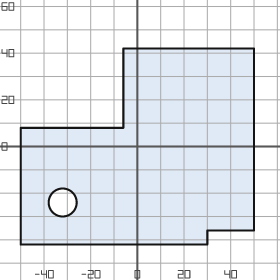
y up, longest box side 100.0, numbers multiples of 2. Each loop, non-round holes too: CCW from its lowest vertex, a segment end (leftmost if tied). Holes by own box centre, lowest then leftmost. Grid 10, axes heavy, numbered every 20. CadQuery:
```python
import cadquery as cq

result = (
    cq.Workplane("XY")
    .moveTo(-50.0, -42.0)
    .lineTo(30.0, -42.0)
    .lineTo(30.0, -36.0)
    .lineTo(50.0, -36.0)
    .lineTo(50.0, 42.0)
    .lineTo(-6.0, 42.0)
    .lineTo(-6.0, 8.0)
    .lineTo(-50.0, 8.0)
    .close()
    .moveTo(-32.0, -24.0)
    .circle(6.0)
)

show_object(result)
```